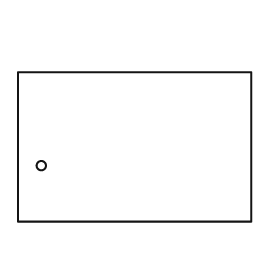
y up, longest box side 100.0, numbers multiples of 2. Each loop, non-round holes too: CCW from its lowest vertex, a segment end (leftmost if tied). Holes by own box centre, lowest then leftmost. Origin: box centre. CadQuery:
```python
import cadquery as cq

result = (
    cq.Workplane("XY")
    .moveTo(-50.0, -32.0)
    .lineTo(50.0, -32.0)
    .lineTo(50.0, 32.0)
    .lineTo(-50.0, 32.0)
    .close()
    .moveTo(-40.0, -8.0)
    .circle(2.0)
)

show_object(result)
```